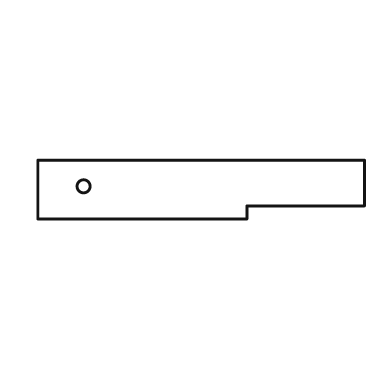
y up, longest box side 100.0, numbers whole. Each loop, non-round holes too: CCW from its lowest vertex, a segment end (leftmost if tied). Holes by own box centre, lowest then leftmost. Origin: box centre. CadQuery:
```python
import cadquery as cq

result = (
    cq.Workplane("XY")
    .moveTo(-50.0, -9.0)
    .lineTo(14.0, -9.0)
    .lineTo(14.0, -5.0)
    .lineTo(50.0, -5.0)
    .lineTo(50.0, 9.0)
    .lineTo(-50.0, 9.0)
    .close()
    .moveTo(-36.0, 1.0)
    .circle(2.0)
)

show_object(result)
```